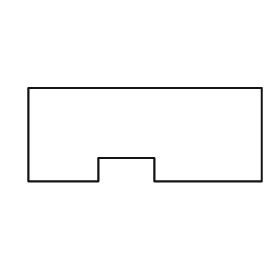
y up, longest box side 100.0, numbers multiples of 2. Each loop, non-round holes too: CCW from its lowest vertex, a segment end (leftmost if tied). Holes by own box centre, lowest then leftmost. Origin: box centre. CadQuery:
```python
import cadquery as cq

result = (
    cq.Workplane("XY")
    .moveTo(-50.0, -20.0)
    .lineTo(-20.0, -20.0)
    .lineTo(-20.0, -10.0)
    .lineTo(4.0, -10.0)
    .lineTo(4.0, -20.0)
    .lineTo(50.0, -20.0)
    .lineTo(50.0, 20.0)
    .lineTo(-50.0, 20.0)
    .close()
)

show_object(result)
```